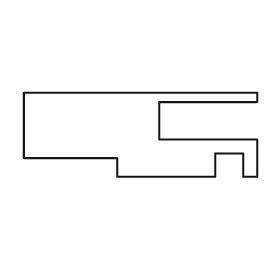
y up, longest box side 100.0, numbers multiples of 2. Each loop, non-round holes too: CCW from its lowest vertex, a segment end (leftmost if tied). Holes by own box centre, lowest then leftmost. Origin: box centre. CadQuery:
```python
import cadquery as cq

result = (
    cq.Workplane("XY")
    .moveTo(-10.0, -18.0)
    .lineTo(32.0, -18.0)
    .lineTo(32.0, -8.0)
    .lineTo(44.0, -8.0)
    .lineTo(44.0, -18.0)
    .lineTo(50.0, -18.0)
    .lineTo(50.0, -2.0)
    .lineTo(8.0, -2.0)
    .lineTo(8.0, 14.0)
    .lineTo(50.0, 14.0)
    .lineTo(50.0, 18.0)
    .lineTo(-50.0, 18.0)
    .lineTo(-50.0, -10.0)
    .lineTo(-10.0, -10.0)
    .close()
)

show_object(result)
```